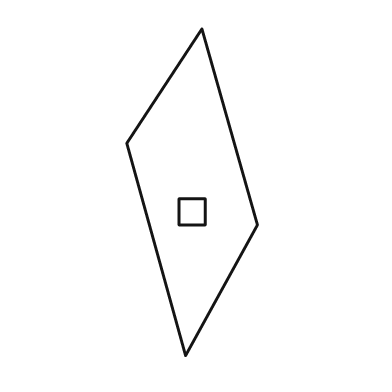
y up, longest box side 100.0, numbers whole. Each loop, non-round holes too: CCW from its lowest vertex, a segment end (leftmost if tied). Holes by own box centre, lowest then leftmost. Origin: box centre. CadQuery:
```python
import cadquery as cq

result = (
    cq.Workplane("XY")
    .moveTo(-2.0, -50.0)
    .lineTo(20.0, -10.0)
    .lineTo(3.0, 50.0)
    .lineTo(-20.0, 15.0)
    .close()
    .moveTo(-4.0, -10.0)
    .lineTo(4.0, -10.0)
    .lineTo(4.0, -2.0)
    .lineTo(-4.0, -2.0)
    .close()
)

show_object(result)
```